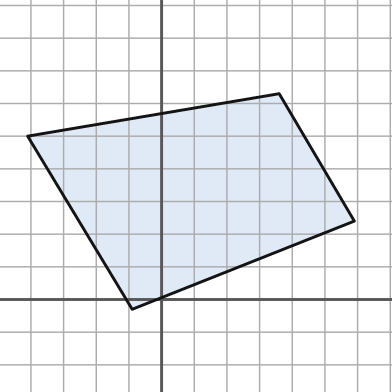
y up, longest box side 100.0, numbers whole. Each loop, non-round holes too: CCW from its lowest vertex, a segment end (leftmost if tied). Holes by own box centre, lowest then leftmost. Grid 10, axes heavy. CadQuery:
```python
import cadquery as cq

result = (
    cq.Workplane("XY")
    .moveTo(-9.0, -3.0)
    .lineTo(59.0, 24.0)
    .lineTo(36.0, 63.0)
    .lineTo(-41.0, 50.0)
    .close()
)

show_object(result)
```